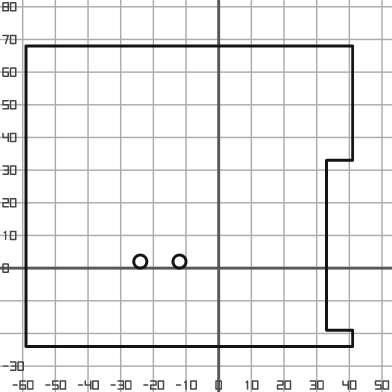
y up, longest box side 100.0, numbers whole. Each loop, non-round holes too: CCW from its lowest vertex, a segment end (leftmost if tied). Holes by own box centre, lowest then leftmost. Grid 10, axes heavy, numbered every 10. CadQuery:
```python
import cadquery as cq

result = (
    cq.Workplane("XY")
    .moveTo(-59.0, -24.0)
    .lineTo(41.0, -24.0)
    .lineTo(41.0, -19.0)
    .lineTo(33.0, -19.0)
    .lineTo(33.0, 33.0)
    .lineTo(41.0, 33.0)
    .lineTo(41.0, 68.0)
    .lineTo(-59.0, 68.0)
    .close()
    .moveTo(-24.0, 2.0)
    .circle(2.0)
    .moveTo(-12.0, 2.0)
    .circle(2.0)
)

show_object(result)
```